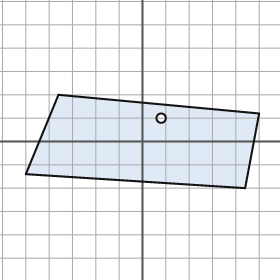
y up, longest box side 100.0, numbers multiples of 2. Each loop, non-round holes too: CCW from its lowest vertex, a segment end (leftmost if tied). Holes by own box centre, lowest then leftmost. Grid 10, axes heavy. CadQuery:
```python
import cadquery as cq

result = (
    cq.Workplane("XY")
    .moveTo(44.0, -20.0)
    .lineTo(50.0, 12.0)
    .lineTo(-36.0, 20.0)
    .lineTo(-50.0, -14.0)
    .close()
    .moveTo(8.0, 10.0)
    .circle(2.0)
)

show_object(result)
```